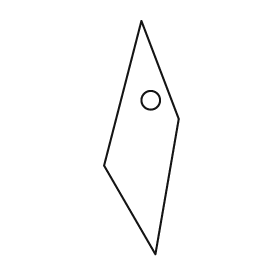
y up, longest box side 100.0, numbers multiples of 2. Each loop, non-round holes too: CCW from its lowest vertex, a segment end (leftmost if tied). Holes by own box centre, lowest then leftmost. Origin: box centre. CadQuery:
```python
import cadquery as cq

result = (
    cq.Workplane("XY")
    .moveTo(6.0, -50.0)
    .lineTo(16.0, 8.0)
    .lineTo(0.0, 50.0)
    .lineTo(-16.0, -12.0)
    .close()
    .moveTo(4.0, 16.0)
    .circle(4.0)
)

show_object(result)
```